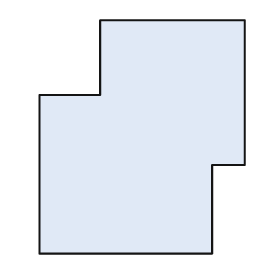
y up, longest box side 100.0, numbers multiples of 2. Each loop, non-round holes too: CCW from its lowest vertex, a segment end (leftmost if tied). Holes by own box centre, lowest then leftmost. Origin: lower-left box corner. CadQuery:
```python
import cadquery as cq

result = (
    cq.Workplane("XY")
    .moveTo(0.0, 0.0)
    .lineTo(74.0, 0.0)
    .lineTo(74.0, 38.0)
    .lineTo(88.0, 38.0)
    .lineTo(88.0, 100.0)
    .lineTo(26.0, 100.0)
    .lineTo(26.0, 68.0)
    .lineTo(0.0, 68.0)
    .close()
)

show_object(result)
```